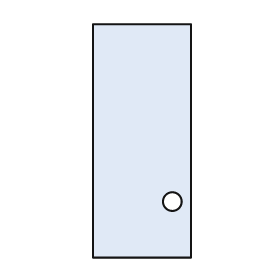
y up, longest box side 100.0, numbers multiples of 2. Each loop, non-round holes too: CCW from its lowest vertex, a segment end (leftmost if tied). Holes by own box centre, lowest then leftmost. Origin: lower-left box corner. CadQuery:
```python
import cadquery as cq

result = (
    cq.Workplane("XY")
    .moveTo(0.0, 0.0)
    .lineTo(42.0, 0.0)
    .lineTo(42.0, 100.0)
    .lineTo(0.0, 100.0)
    .close()
    .moveTo(34.0, 24.0)
    .circle(4.0)
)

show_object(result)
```